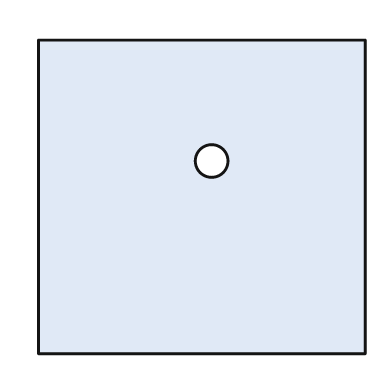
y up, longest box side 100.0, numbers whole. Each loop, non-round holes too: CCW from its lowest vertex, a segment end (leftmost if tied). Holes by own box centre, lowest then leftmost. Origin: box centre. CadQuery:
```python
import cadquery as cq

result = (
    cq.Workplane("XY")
    .moveTo(-50.0, -48.0)
    .lineTo(50.0, -48.0)
    .lineTo(50.0, 48.0)
    .lineTo(-50.0, 48.0)
    .close()
    .moveTo(3.0, 11.0)
    .circle(5.0)
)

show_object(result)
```